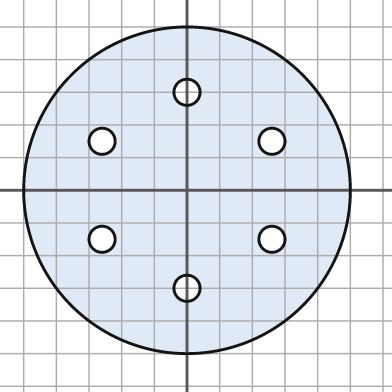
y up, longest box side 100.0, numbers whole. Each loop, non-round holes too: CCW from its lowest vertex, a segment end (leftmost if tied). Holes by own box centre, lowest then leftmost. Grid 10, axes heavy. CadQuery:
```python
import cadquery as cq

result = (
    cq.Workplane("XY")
    .moveTo(0.0, 0.0)
    .circle(50.0)
    .moveTo(0.0, -30.0)
    .circle(4.0)
    .moveTo(-26.0, -15.0)
    .circle(4.0)
    .moveTo(26.0, -15.0)
    .circle(4.0)
    .moveTo(-26.0, 15.0)
    .circle(4.0)
    .moveTo(26.0, 15.0)
    .circle(4.0)
    .moveTo(0.0, 30.0)
    .circle(4.0)
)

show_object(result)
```